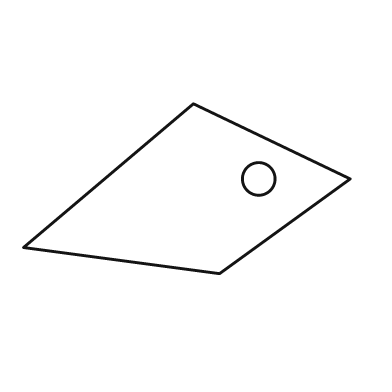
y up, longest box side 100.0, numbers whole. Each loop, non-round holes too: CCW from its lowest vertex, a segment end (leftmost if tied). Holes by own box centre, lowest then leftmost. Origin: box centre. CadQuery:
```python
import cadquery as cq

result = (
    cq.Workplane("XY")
    .moveTo(10.0, -26.0)
    .lineTo(50.0, 3.0)
    .lineTo(2.0, 26.0)
    .lineTo(-50.0, -18.0)
    .close()
    .moveTo(22.0, 3.0)
    .circle(5.0)
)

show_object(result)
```